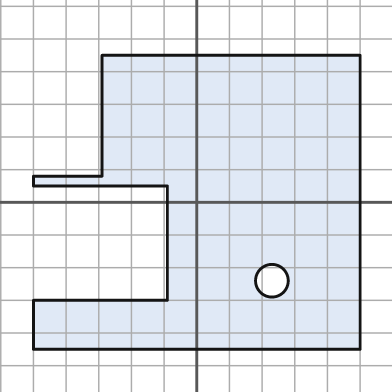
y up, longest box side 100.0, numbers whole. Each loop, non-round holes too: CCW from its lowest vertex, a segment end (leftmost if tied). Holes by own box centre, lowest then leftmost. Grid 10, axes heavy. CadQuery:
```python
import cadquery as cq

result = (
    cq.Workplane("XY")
    .moveTo(-50.0, -45.0)
    .lineTo(50.0, -45.0)
    .lineTo(50.0, 45.0)
    .lineTo(-29.0, 45.0)
    .lineTo(-29.0, 8.0)
    .lineTo(-50.0, 8.0)
    .lineTo(-50.0, 5.0)
    .lineTo(-9.0, 5.0)
    .lineTo(-9.0, -30.0)
    .lineTo(-50.0, -30.0)
    .close()
    .moveTo(23.0, -24.0)
    .circle(5.0)
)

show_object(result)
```